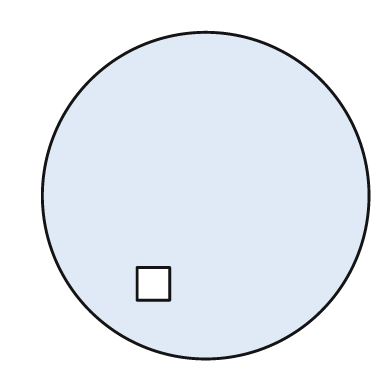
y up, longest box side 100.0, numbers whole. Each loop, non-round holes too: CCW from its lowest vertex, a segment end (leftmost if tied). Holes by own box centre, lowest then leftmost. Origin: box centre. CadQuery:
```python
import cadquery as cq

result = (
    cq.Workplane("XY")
    .moveTo(0.0, 0.0)
    .circle(50.0)
    .moveTo(-21.0, -32.0)
    .lineTo(-11.0, -32.0)
    .lineTo(-11.0, -22.0)
    .lineTo(-21.0, -22.0)
    .close()
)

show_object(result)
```